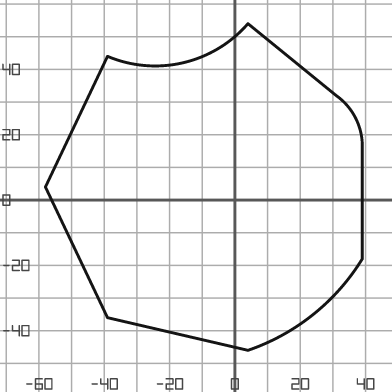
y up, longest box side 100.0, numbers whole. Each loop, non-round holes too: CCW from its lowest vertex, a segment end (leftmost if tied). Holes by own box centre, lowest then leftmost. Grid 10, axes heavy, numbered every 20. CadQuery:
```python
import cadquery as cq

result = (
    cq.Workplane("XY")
    .moveTo(4.0, -46.0)
    .threePointArc((24.0, -35.0), (39.0, -18.0))
    .lineTo(39.0, 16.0)
    .threePointArc((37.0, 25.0), (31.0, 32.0))
    .lineTo(4.0, 54.0)
    .threePointArc((-16.0, 42.0), (-39.0, 44.0))
    .lineTo(-58.0, 4.0)
    .lineTo(-39.0, -36.0)
    .close()
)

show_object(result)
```